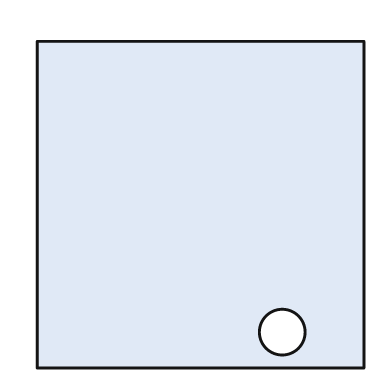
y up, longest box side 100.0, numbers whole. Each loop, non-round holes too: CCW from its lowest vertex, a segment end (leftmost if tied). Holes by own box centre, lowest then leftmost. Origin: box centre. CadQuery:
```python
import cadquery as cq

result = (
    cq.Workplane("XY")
    .moveTo(-50.0, -50.0)
    .lineTo(50.0, -50.0)
    .lineTo(50.0, 50.0)
    .lineTo(-50.0, 50.0)
    .close()
    .moveTo(25.0, -39.0)
    .circle(7.0)
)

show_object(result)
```